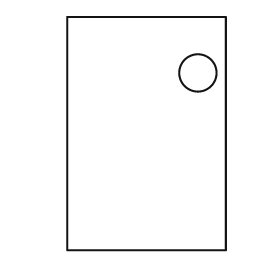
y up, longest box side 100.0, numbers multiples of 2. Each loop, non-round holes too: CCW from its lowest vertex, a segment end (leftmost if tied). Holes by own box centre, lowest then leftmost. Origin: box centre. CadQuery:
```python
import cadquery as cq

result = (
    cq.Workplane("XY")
    .moveTo(-34.0, -50.0)
    .lineTo(34.0, -50.0)
    .lineTo(34.0, 50.0)
    .lineTo(-34.0, 50.0)
    .close()
    .moveTo(22.0, 26.0)
    .circle(8.0)
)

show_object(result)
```